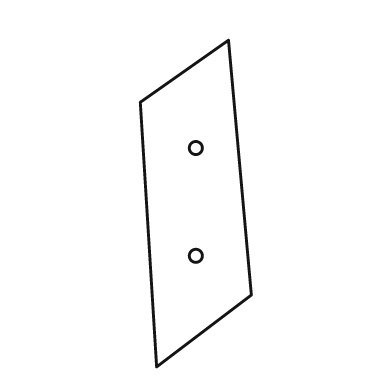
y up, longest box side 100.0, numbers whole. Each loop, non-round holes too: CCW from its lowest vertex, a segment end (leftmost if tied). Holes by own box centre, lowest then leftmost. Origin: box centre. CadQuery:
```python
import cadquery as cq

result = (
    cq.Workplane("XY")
    .moveTo(-12.0, -50.0)
    .lineTo(17.0, -28.0)
    .lineTo(10.0, 50.0)
    .lineTo(-17.0, 31.0)
    .close()
    .moveTo(0.0, -16.0)
    .circle(2.0)
    .moveTo(0.0, 17.0)
    .circle(2.0)
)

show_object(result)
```